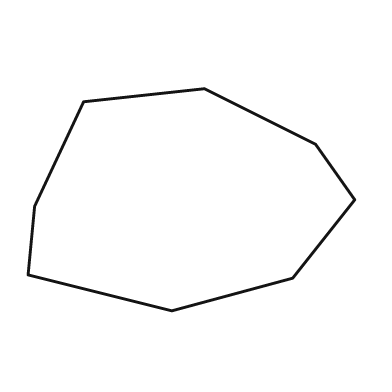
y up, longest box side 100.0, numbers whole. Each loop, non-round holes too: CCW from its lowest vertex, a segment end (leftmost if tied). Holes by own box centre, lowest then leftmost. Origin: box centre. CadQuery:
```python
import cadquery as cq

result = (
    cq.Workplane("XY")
    .moveTo(-6.0, -34.0)
    .lineTo(31.0, -24.0)
    .lineTo(50.0, 0.0)
    .lineTo(38.0, 17.0)
    .lineTo(4.0, 34.0)
    .lineTo(-33.0, 30.0)
    .lineTo(-48.0, -2.0)
    .lineTo(-50.0, -23.0)
    .close()
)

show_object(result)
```